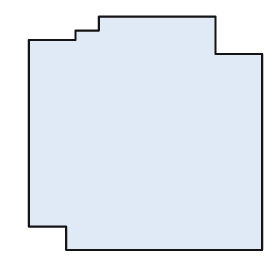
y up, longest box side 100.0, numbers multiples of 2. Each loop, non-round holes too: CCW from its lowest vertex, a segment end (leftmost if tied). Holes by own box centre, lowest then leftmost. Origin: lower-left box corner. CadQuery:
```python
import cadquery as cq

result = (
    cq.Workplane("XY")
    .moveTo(16.0, 0.0)
    .lineTo(100.0, 0.0)
    .lineTo(100.0, 84.0)
    .lineTo(80.0, 84.0)
    .lineTo(80.0, 100.0)
    .lineTo(30.0, 100.0)
    .lineTo(30.0, 94.0)
    .lineTo(20.0, 94.0)
    .lineTo(20.0, 90.0)
    .lineTo(0.0, 90.0)
    .lineTo(0.0, 10.0)
    .lineTo(16.0, 10.0)
    .close()
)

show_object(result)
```